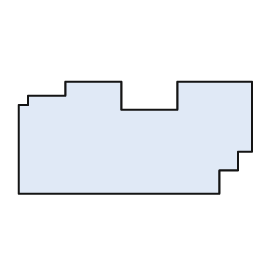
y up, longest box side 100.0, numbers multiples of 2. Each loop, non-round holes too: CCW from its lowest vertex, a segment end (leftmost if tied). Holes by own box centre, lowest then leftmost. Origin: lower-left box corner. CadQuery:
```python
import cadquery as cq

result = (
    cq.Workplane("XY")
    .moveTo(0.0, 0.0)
    .lineTo(86.0, 0.0)
    .lineTo(86.0, 10.0)
    .lineTo(94.0, 10.0)
    .lineTo(94.0, 18.0)
    .lineTo(100.0, 18.0)
    .lineTo(100.0, 48.0)
    .lineTo(68.0, 48.0)
    .lineTo(68.0, 36.0)
    .lineTo(44.0, 36.0)
    .lineTo(44.0, 48.0)
    .lineTo(20.0, 48.0)
    .lineTo(20.0, 42.0)
    .lineTo(4.0, 42.0)
    .lineTo(4.0, 38.0)
    .lineTo(0.0, 38.0)
    .close()
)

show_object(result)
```